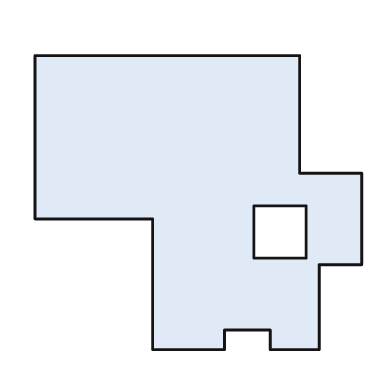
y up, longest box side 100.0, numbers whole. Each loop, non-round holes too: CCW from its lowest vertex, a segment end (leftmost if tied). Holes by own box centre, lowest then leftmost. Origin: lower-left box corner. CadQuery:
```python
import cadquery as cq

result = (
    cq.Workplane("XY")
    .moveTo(36.0, 0.0)
    .lineTo(58.0, 0.0)
    .lineTo(58.0, 6.0)
    .lineTo(72.0, 6.0)
    .lineTo(72.0, 0.0)
    .lineTo(87.0, 0.0)
    .lineTo(87.0, 26.0)
    .lineTo(100.0, 26.0)
    .lineTo(100.0, 54.0)
    .lineTo(81.0, 54.0)
    .lineTo(81.0, 90.0)
    .lineTo(0.0, 90.0)
    .lineTo(0.0, 40.0)
    .lineTo(36.0, 40.0)
    .close()
    .moveTo(67.0, 28.0)
    .lineTo(83.0, 28.0)
    .lineTo(83.0, 44.0)
    .lineTo(67.0, 44.0)
    .close()
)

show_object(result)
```